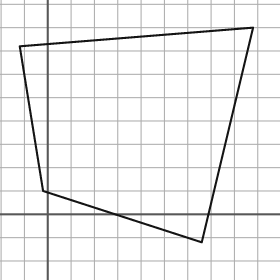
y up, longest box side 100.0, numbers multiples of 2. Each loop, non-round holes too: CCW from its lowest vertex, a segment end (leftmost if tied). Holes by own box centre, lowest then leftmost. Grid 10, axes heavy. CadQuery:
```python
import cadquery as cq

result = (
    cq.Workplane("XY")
    .moveTo(66.0, -12.0)
    .lineTo(88.0, 80.0)
    .lineTo(-12.0, 72.0)
    .lineTo(-2.0, 10.0)
    .close()
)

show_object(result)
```